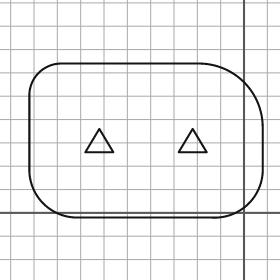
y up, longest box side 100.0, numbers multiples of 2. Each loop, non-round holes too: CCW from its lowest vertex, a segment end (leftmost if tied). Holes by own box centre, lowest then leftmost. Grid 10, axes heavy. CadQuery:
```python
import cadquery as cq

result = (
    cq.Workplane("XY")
    .moveTo(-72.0, -2.0)
    .lineTo(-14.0, -2.0)
    .threePointArc((2.0, 4.0), (8.0, 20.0))
    .lineTo(8.0, 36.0)
    .threePointArc((0.0, 56.0), (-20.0, 64.0))
    .lineTo(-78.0, 64.0)
    .threePointArc((-88.0, 60.0), (-92.0, 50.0))
    .lineTo(-92.0, 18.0)
    .threePointArc((-86.0, 4.0), (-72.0, -2.0))
    .close()
    .moveTo(-68.0, 26.0)
    .lineTo(-56.0, 26.0)
    .lineTo(-62.0, 36.0)
    .close()
    .moveTo(-28.0, 26.0)
    .lineTo(-16.0, 26.0)
    .lineTo(-22.0, 36.0)
    .close()
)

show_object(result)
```